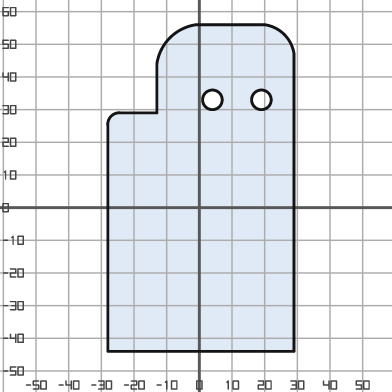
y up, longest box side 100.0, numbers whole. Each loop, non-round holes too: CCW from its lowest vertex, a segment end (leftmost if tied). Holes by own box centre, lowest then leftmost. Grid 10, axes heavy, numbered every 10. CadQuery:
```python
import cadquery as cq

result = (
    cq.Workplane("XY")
    .moveTo(-28.0, -44.0)
    .lineTo(29.0, -44.0)
    .lineTo(29.0, 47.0)
    .threePointArc((26.0, 53.0), (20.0, 56.0))
    .lineTo(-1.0, 56.0)
    .threePointArc((-9.0, 52.0), (-13.0, 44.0))
    .lineTo(-13.0, 29.0)
    .lineTo(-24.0, 29.0)
    .threePointArc((-27.0, 28.0), (-28.0, 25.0))
    .close()
    .moveTo(4.0, 33.0)
    .circle(3.0)
    .moveTo(19.0, 33.0)
    .circle(3.0)
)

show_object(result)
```